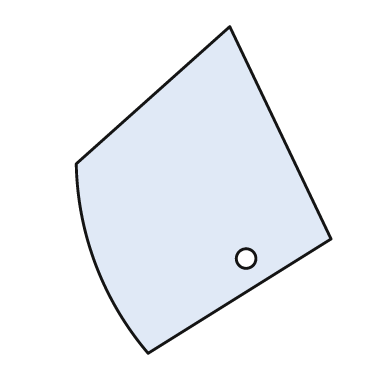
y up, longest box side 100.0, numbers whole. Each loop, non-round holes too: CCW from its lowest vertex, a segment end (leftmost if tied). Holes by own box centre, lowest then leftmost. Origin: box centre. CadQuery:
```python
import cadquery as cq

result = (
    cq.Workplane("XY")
    .moveTo(-17.0, -50.0)
    .lineTo(39.0, -15.0)
    .lineTo(8.0, 50.0)
    .lineTo(-39.0, 8.0)
    .threePointArc((-33.0, -23.0), (-17.0, -50.0))
    .close()
    .moveTo(13.0, -21.0)
    .circle(3.0)
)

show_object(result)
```